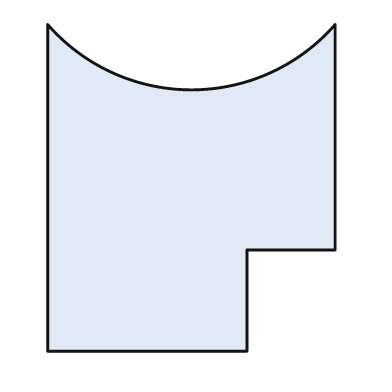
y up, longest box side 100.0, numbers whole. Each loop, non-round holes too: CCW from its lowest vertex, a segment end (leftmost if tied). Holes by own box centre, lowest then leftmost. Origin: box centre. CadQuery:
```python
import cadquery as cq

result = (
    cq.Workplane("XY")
    .moveTo(-44.0, -50.0)
    .lineTo(17.0, -50.0)
    .lineTo(17.0, -19.0)
    .lineTo(44.0, -19.0)
    .lineTo(44.0, 50.0)
    .threePointArc((0.0, 30.0), (-44.0, 50.0))
    .close()
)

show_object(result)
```